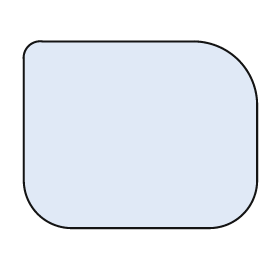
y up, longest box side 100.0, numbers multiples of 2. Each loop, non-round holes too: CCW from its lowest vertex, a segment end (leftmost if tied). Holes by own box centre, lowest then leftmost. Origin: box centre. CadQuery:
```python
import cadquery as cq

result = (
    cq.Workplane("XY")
    .moveTo(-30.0, -40.0)
    .lineTo(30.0, -40.0)
    .threePointArc((44.0, -34.0), (50.0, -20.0))
    .lineTo(50.0, 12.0)
    .threePointArc((42.0, 32.0), (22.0, 40.0))
    .lineTo(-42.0, 40.0)
    .threePointArc((-48.0, 38.0), (-50.0, 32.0))
    .lineTo(-50.0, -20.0)
    .threePointArc((-44.0, -34.0), (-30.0, -40.0))
    .close()
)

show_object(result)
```